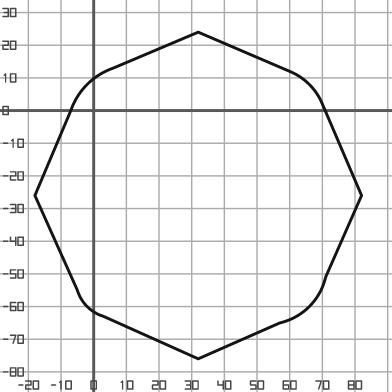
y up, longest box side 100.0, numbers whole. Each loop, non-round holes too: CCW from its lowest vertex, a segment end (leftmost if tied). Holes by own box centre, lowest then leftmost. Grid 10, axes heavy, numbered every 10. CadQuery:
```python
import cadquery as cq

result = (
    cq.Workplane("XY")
    .moveTo(32.0, -76.0)
    .lineTo(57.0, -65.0)
    .threePointArc((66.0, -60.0), (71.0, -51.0))
    .lineTo(82.0, -26.0)
    .lineTo(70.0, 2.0)
    .threePointArc((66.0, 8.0), (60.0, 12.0))
    .lineTo(32.0, 24.0)
    .lineTo(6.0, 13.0)
    .threePointArc((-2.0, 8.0), (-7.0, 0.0))
    .lineTo(-18.0, -26.0)
    .lineTo(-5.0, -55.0)
    .threePointArc((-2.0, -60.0), (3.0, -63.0))
    .close()
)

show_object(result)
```